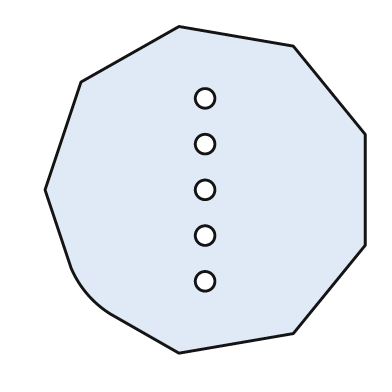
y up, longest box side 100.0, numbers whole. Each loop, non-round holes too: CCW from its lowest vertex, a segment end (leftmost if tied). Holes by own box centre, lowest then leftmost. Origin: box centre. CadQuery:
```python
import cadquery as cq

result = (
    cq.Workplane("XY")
    .moveTo(-8.0, -50.0)
    .lineTo(27.0, -44.0)
    .lineTo(49.0, -17.0)
    .lineTo(49.0, 17.0)
    .lineTo(27.0, 44.0)
    .lineTo(-8.0, 50.0)
    .lineTo(-38.0, 33.0)
    .lineTo(-49.0, 0.0)
    .lineTo(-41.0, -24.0)
    .threePointArc((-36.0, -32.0), (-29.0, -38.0))
    .close()
    .moveTo(0.0, -28.0)
    .circle(3.0)
    .moveTo(0.0, -14.0)
    .circle(3.0)
    .moveTo(0.0, 0.0)
    .circle(3.0)
    .moveTo(0.0, 14.0)
    .circle(3.0)
    .moveTo(0.0, 28.0)
    .circle(3.0)
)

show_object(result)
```